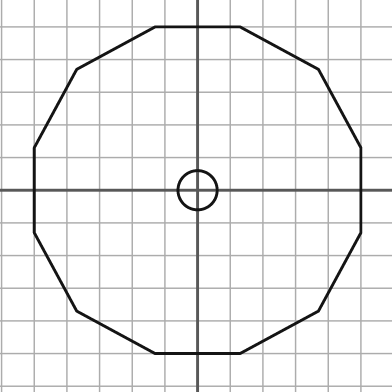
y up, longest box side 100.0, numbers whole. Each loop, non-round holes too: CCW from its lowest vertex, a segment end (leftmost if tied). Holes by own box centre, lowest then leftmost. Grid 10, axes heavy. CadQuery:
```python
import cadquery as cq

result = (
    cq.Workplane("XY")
    .moveTo(-13.0, -50.0)
    .lineTo(13.0, -50.0)
    .lineTo(37.0, -37.0)
    .lineTo(50.0, -13.0)
    .lineTo(50.0, 13.0)
    .lineTo(37.0, 37.0)
    .lineTo(13.0, 50.0)
    .lineTo(-13.0, 50.0)
    .lineTo(-37.0, 37.0)
    .lineTo(-50.0, 13.0)
    .lineTo(-50.0, -13.0)
    .lineTo(-37.0, -37.0)
    .close()
    .moveTo(0.0, 0.0)
    .circle(6.0)
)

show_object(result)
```